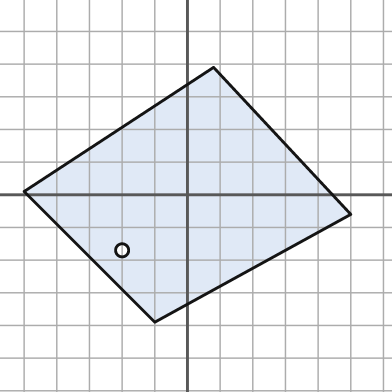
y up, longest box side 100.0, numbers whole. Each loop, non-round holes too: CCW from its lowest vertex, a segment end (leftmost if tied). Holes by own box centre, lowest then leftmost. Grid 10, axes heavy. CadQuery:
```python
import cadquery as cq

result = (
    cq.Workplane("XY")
    .moveTo(-10.0, -39.0)
    .lineTo(50.0, -6.0)
    .lineTo(8.0, 39.0)
    .lineTo(-50.0, 1.0)
    .close()
    .moveTo(-20.0, -17.0)
    .circle(2.0)
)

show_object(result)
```